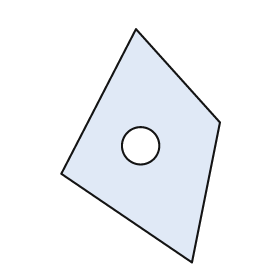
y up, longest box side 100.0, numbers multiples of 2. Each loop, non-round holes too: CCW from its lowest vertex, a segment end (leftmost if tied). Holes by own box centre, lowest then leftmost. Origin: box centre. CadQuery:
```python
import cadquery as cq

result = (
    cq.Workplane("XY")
    .moveTo(22.0, -50.0)
    .lineTo(34.0, 10.0)
    .lineTo(-2.0, 50.0)
    .lineTo(-34.0, -12.0)
    .close()
    .moveTo(0.0, 0.0)
    .circle(8.0)
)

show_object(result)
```